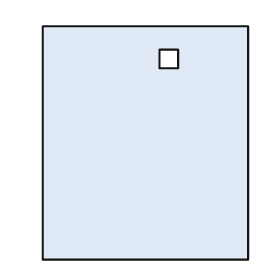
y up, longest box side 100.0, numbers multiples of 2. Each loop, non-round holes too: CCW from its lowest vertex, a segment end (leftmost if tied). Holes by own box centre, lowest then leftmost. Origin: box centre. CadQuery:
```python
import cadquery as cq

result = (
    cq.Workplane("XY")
    .moveTo(-44.0, -50.0)
    .lineTo(44.0, -50.0)
    .lineTo(44.0, 50.0)
    .lineTo(-44.0, 50.0)
    .close()
    .moveTo(6.0, 32.0)
    .lineTo(14.0, 32.0)
    .lineTo(14.0, 40.0)
    .lineTo(6.0, 40.0)
    .close()
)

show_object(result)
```